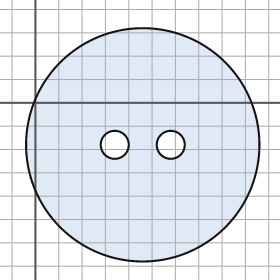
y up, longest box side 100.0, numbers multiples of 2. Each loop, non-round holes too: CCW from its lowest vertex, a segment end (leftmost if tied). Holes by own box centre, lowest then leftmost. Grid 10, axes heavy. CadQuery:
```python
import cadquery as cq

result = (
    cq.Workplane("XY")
    .moveTo(46.0, -18.0)
    .circle(50.0)
    .moveTo(34.0, -18.0)
    .circle(6.0)
    .moveTo(58.0, -18.0)
    .circle(6.0)
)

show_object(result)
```